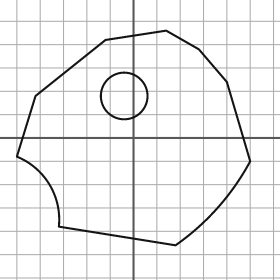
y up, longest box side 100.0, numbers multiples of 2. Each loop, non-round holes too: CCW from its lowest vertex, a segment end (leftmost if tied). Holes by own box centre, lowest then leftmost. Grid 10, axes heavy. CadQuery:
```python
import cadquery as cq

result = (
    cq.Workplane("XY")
    .moveTo(18.0, -46.0)
    .threePointArc((36.0, -30.0), (50.0, -10.0))
    .lineTo(40.0, 24.0)
    .lineTo(28.0, 38.0)
    .lineTo(14.0, 46.0)
    .lineTo(-12.0, 42.0)
    .lineTo(-42.0, 18.0)
    .lineTo(-50.0, -8.0)
    .threePointArc((-36.0, -20.0), (-32.0, -38.0))
    .close()
    .moveTo(-4.0, 18.0)
    .circle(10.0)
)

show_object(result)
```